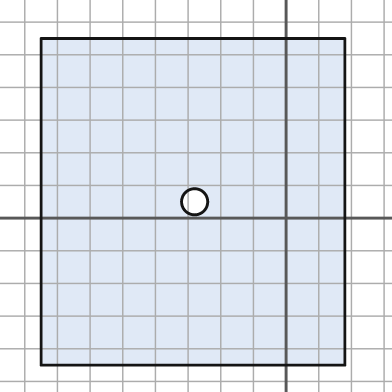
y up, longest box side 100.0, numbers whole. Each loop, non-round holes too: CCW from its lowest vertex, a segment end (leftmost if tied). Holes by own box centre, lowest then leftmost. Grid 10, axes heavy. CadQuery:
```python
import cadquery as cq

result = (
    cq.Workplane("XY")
    .moveTo(-75.0, -45.0)
    .lineTo(18.0, -45.0)
    .lineTo(18.0, 55.0)
    .lineTo(-75.0, 55.0)
    .close()
    .moveTo(-28.0, 5.0)
    .circle(4.0)
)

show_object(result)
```